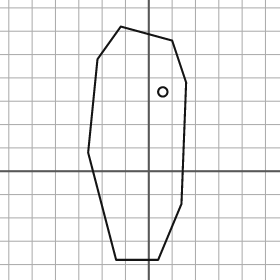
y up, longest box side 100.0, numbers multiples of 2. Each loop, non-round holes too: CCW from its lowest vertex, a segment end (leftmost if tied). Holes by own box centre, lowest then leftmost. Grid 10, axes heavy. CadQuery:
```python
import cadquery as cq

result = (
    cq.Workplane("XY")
    .moveTo(-14.0, -38.0)
    .lineTo(4.0, -38.0)
    .lineTo(14.0, -14.0)
    .lineTo(16.0, 38.0)
    .lineTo(10.0, 56.0)
    .lineTo(-12.0, 62.0)
    .lineTo(-22.0, 48.0)
    .lineTo(-26.0, 8.0)
    .close()
    .moveTo(6.0, 34.0)
    .circle(2.0)
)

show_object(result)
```